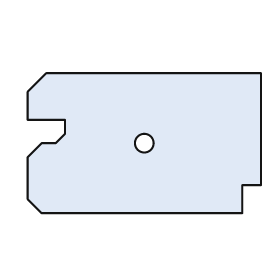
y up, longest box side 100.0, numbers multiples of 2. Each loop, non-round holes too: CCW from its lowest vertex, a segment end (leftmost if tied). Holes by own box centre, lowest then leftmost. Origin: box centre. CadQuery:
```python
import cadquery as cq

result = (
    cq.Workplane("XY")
    .moveTo(-44.0, -30.0)
    .lineTo(42.0, -30.0)
    .lineTo(42.0, -18.0)
    .lineTo(50.0, -18.0)
    .lineTo(50.0, 30.0)
    .lineTo(-42.0, 30.0)
    .lineTo(-50.0, 22.0)
    .lineTo(-50.0, 10.0)
    .lineTo(-34.0, 10.0)
    .lineTo(-34.0, 4.0)
    .lineTo(-38.0, 0.0)
    .lineTo(-44.0, 0.0)
    .lineTo(-50.0, -6.0)
    .lineTo(-50.0, -24.0)
    .close()
    .moveTo(0.0, 0.0)
    .circle(4.0)
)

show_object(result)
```